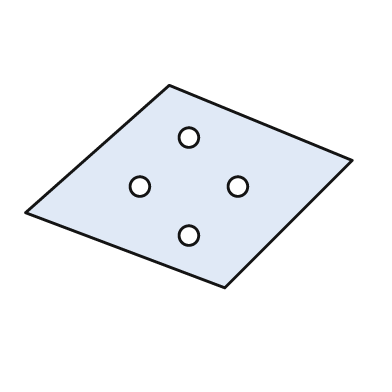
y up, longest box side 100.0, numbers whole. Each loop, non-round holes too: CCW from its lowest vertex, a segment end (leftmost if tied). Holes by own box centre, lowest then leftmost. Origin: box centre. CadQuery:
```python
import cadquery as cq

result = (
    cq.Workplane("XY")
    .moveTo(11.0, -31.0)
    .lineTo(50.0, 8.0)
    .lineTo(-6.0, 31.0)
    .lineTo(-50.0, -8.0)
    .close()
    .moveTo(0.0, -15.0)
    .circle(3.0)
    .moveTo(-15.0, 0.0)
    .circle(3.0)
    .moveTo(15.0, 0.0)
    .circle(3.0)
    .moveTo(0.0, 15.0)
    .circle(3.0)
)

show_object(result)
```